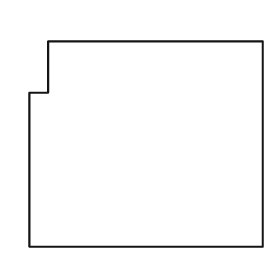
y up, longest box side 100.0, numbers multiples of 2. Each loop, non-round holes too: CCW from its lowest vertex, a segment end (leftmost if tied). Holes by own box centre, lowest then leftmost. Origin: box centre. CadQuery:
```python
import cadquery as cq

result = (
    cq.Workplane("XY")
    .moveTo(-50.0, -44.0)
    .lineTo(50.0, -44.0)
    .lineTo(50.0, 44.0)
    .lineTo(-42.0, 44.0)
    .lineTo(-42.0, 22.0)
    .lineTo(-50.0, 22.0)
    .close()
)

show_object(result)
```